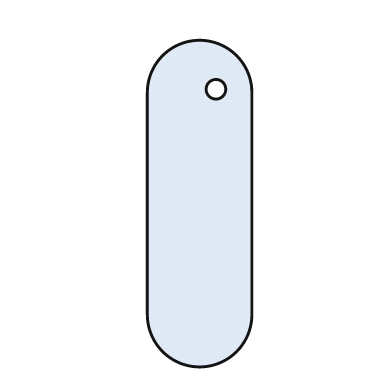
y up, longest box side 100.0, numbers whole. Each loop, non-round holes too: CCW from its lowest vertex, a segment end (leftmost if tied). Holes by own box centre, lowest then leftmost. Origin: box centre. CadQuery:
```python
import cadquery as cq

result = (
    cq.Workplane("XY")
    .moveTo(-16.0, -34.0)
    .threePointArc((0.0, -50.0), (16.0, -34.0))
    .lineTo(16.0, 34.0)
    .threePointArc((0.0, 50.0), (-16.0, 34.0))
    .close()
    .moveTo(5.0, 35.0)
    .circle(3.0)
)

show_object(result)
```